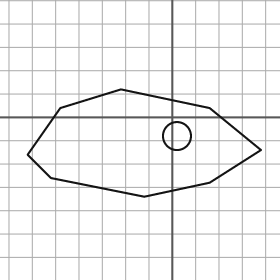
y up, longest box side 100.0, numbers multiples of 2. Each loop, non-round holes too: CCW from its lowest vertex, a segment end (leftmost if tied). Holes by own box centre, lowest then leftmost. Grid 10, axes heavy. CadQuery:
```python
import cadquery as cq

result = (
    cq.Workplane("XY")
    .moveTo(-12.0, -34.0)
    .lineTo(16.0, -28.0)
    .lineTo(38.0, -14.0)
    .lineTo(16.0, 4.0)
    .lineTo(-22.0, 12.0)
    .lineTo(-48.0, 4.0)
    .lineTo(-62.0, -16.0)
    .lineTo(-52.0, -26.0)
    .close()
    .moveTo(2.0, -8.0)
    .circle(6.0)
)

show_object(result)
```